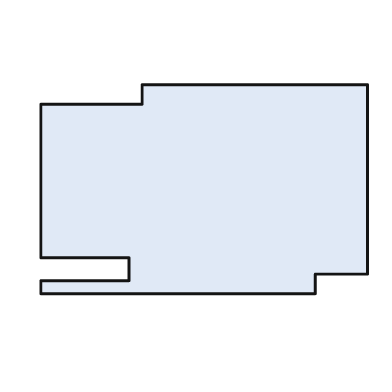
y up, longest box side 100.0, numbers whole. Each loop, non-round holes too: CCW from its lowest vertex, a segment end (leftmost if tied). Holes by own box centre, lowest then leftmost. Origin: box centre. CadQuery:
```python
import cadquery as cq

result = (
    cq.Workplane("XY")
    .moveTo(-50.0, -32.0)
    .lineTo(34.0, -32.0)
    .lineTo(34.0, -26.0)
    .lineTo(50.0, -26.0)
    .lineTo(50.0, 32.0)
    .lineTo(-19.0, 32.0)
    .lineTo(-19.0, 26.0)
    .lineTo(-50.0, 26.0)
    .lineTo(-50.0, -21.0)
    .lineTo(-23.0, -21.0)
    .lineTo(-23.0, -28.0)
    .lineTo(-50.0, -28.0)
    .close()
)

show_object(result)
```